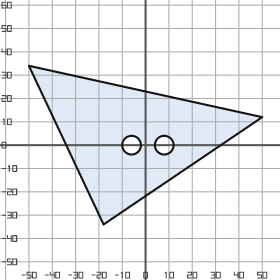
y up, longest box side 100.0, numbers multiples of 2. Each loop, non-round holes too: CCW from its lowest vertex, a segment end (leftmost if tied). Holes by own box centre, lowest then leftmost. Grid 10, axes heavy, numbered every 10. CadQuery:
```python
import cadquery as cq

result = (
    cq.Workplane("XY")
    .moveTo(-18.0, -34.0)
    .lineTo(50.0, 12.0)
    .lineTo(-50.0, 34.0)
    .close()
    .moveTo(-6.0, 0.0)
    .circle(4.0)
    .moveTo(8.0, 0.0)
    .circle(4.0)
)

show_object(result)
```